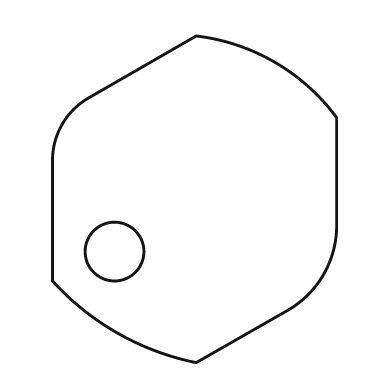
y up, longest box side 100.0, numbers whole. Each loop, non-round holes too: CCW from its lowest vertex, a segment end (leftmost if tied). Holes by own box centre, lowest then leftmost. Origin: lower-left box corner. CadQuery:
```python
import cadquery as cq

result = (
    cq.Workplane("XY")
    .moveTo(44.0, 0.0)
    .lineTo(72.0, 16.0)
    .threePointArc((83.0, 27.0), (87.0, 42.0))
    .lineTo(87.0, 75.0)
    .threePointArc((68.0, 92.0), (44.0, 100.0))
    .lineTo(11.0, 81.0)
    .threePointArc((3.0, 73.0), (0.0, 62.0))
    .lineTo(0.0, 25.0)
    .threePointArc((20.0, 9.0), (44.0, 0.0))
    .close()
    .moveTo(19.0, 34.0)
    .circle(9.0)
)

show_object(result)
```